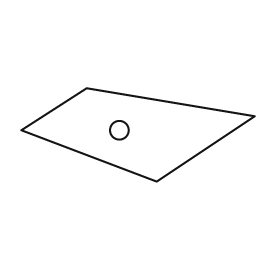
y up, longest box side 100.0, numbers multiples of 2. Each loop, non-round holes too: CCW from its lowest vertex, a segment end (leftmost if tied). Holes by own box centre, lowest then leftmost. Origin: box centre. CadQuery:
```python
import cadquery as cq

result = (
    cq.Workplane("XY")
    .moveTo(8.0, -20.0)
    .lineTo(50.0, 8.0)
    .lineTo(-22.0, 20.0)
    .lineTo(-50.0, 2.0)
    .close()
    .moveTo(-8.0, 2.0)
    .circle(4.0)
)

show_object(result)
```